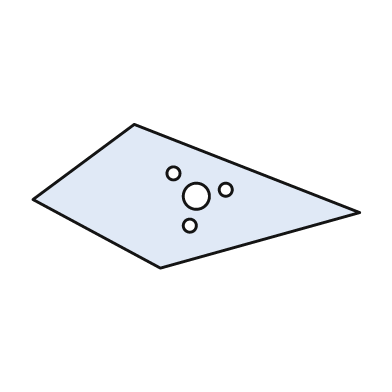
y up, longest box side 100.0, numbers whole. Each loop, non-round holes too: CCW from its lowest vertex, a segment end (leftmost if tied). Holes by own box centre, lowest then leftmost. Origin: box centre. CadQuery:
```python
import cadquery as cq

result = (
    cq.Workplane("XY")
    .moveTo(-11.0, -22.0)
    .lineTo(50.0, -5.0)
    .lineTo(-19.0, 22.0)
    .lineTo(-50.0, -1.0)
    .close()
    .moveTo(-2.0, -9.0)
    .circle(2.0)
    .moveTo(0.0, 0.0)
    .circle(4.0)
    .moveTo(9.0, 2.0)
    .circle(2.0)
    .moveTo(-7.0, 7.0)
    .circle(2.0)
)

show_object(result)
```